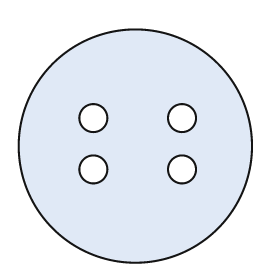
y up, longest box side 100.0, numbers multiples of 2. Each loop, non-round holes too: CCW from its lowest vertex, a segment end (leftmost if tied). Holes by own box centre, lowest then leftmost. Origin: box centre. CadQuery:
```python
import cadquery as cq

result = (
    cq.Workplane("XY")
    .moveTo(0.0, 0.0)
    .circle(50.0)
    .moveTo(-18.0, -10.0)
    .circle(6.0)
    .moveTo(20.0, -10.0)
    .circle(6.0)
    .moveTo(-18.0, 12.0)
    .circle(6.0)
    .moveTo(20.0, 12.0)
    .circle(6.0)
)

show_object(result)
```